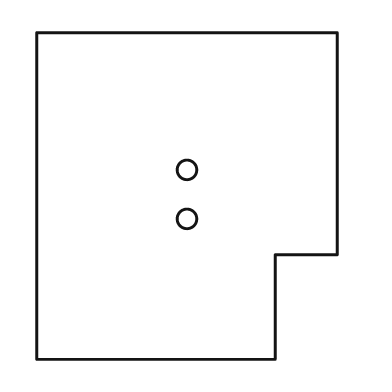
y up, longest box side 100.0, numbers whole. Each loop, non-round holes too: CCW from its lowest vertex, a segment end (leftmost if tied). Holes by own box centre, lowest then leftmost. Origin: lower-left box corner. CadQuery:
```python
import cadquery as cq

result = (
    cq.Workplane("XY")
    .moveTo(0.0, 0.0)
    .lineTo(73.0, 0.0)
    .lineTo(73.0, 32.0)
    .lineTo(92.0, 32.0)
    .lineTo(92.0, 100.0)
    .lineTo(0.0, 100.0)
    .close()
    .moveTo(46.0, 43.0)
    .circle(3.0)
    .moveTo(46.0, 58.0)
    .circle(3.0)
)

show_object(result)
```